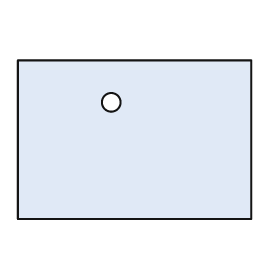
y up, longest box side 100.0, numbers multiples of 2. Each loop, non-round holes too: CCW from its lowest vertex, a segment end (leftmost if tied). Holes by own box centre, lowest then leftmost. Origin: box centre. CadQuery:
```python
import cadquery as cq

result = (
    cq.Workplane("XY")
    .moveTo(-50.0, -34.0)
    .lineTo(50.0, -34.0)
    .lineTo(50.0, 34.0)
    .lineTo(-50.0, 34.0)
    .close()
    .moveTo(-10.0, 16.0)
    .circle(4.0)
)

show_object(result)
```